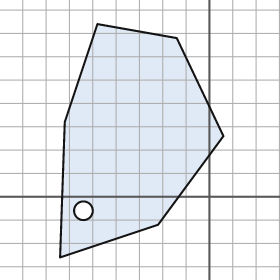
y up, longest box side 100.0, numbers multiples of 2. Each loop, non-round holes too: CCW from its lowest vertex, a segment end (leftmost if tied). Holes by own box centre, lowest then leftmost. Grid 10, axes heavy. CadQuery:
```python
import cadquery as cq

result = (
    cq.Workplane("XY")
    .moveTo(-64.0, -26.0)
    .lineTo(-22.0, -12.0)
    .lineTo(6.0, 26.0)
    .lineTo(-14.0, 68.0)
    .lineTo(-48.0, 74.0)
    .lineTo(-62.0, 32.0)
    .close()
    .moveTo(-54.0, -6.0)
    .circle(4.0)
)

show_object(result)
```